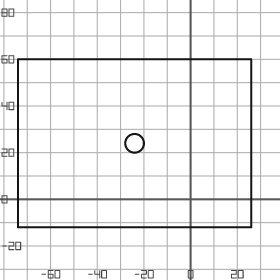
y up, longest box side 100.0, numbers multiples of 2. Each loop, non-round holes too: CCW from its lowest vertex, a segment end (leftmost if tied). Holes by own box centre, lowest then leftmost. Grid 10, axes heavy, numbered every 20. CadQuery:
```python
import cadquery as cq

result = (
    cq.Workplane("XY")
    .moveTo(-74.0, -12.0)
    .lineTo(26.0, -12.0)
    .lineTo(26.0, 60.0)
    .lineTo(-74.0, 60.0)
    .close()
    .moveTo(-24.0, 24.0)
    .circle(4.0)
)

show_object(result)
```